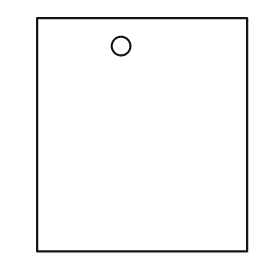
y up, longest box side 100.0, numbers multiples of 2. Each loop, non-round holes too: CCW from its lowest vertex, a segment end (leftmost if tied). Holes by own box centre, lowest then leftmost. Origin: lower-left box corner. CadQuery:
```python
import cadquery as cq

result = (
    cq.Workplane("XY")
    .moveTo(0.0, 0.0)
    .lineTo(90.0, 0.0)
    .lineTo(90.0, 100.0)
    .lineTo(0.0, 100.0)
    .close()
    .moveTo(36.0, 88.0)
    .circle(4.0)
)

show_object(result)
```